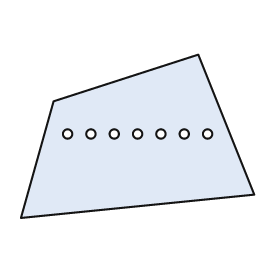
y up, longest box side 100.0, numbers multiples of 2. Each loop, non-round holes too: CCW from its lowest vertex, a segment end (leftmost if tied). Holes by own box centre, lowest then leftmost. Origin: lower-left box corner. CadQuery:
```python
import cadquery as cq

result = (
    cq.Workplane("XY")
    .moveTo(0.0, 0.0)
    .lineTo(100.0, 10.0)
    .lineTo(76.0, 70.0)
    .lineTo(14.0, 50.0)
    .close()
    .moveTo(20.0, 36.0)
    .circle(2.0)
    .moveTo(30.0, 36.0)
    .circle(2.0)
    .moveTo(40.0, 36.0)
    .circle(2.0)
    .moveTo(50.0, 36.0)
    .circle(2.0)
    .moveTo(60.0, 36.0)
    .circle(2.0)
    .moveTo(70.0, 36.0)
    .circle(2.0)
    .moveTo(80.0, 36.0)
    .circle(2.0)
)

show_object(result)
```